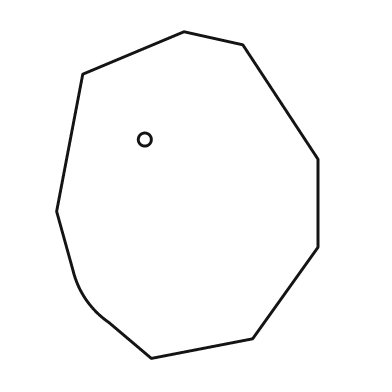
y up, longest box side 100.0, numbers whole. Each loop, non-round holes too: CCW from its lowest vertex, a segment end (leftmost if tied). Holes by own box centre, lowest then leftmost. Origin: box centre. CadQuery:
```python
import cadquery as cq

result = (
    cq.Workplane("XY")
    .moveTo(-11.0, -50.0)
    .lineTo(20.0, -44.0)
    .lineTo(40.0, -16.0)
    .lineTo(40.0, 11.0)
    .lineTo(17.0, 46.0)
    .lineTo(-1.0, 50.0)
    .lineTo(-32.0, 37.0)
    .lineTo(-40.0, -5.0)
    .lineTo(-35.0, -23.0)
    .threePointArc((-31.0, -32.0), (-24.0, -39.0))
    .close()
    .moveTo(-13.0, 17.0)
    .circle(2.0)
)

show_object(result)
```